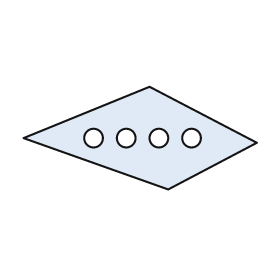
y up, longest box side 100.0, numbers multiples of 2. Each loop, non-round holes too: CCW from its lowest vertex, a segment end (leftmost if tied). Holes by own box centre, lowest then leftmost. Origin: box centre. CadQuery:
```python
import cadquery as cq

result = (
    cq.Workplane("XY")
    .moveTo(12.0, -22.0)
    .lineTo(50.0, -2.0)
    .lineTo(4.0, 22.0)
    .lineTo(-50.0, 0.0)
    .close()
    .moveTo(-20.0, 0.0)
    .circle(4.0)
    .moveTo(-6.0, 0.0)
    .circle(4.0)
    .moveTo(8.0, 0.0)
    .circle(4.0)
    .moveTo(22.0, 0.0)
    .circle(4.0)
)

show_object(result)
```